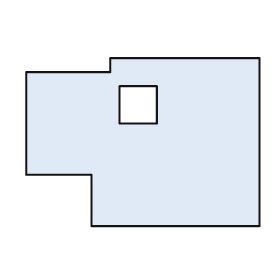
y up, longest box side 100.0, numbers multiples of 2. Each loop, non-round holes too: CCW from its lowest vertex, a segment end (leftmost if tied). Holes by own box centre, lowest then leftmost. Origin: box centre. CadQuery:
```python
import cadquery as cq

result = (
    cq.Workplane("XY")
    .moveTo(-22.0, -36.0)
    .lineTo(50.0, -36.0)
    .lineTo(50.0, 36.0)
    .lineTo(-14.0, 36.0)
    .lineTo(-14.0, 30.0)
    .lineTo(-50.0, 30.0)
    .lineTo(-50.0, -14.0)
    .lineTo(-22.0, -14.0)
    .close()
    .moveTo(-10.0, 8.0)
    .lineTo(6.0, 8.0)
    .lineTo(6.0, 24.0)
    .lineTo(-10.0, 24.0)
    .close()
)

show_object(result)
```